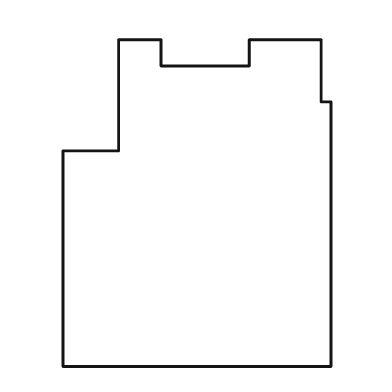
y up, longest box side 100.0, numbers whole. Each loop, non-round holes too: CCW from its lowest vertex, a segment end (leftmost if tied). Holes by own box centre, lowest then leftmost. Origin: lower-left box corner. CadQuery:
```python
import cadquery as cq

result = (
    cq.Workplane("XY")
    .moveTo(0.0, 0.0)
    .lineTo(82.0, 0.0)
    .lineTo(82.0, 81.0)
    .lineTo(79.0, 81.0)
    .lineTo(79.0, 100.0)
    .lineTo(57.0, 100.0)
    .lineTo(57.0, 92.0)
    .lineTo(30.0, 92.0)
    .lineTo(30.0, 100.0)
    .lineTo(17.0, 100.0)
    .lineTo(17.0, 66.0)
    .lineTo(0.0, 66.0)
    .close()
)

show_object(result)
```